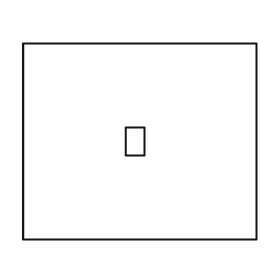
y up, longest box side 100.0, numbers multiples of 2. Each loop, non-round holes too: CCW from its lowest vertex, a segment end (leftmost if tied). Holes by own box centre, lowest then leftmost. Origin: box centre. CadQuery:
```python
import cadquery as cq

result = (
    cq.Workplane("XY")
    .moveTo(-50.0, -42.0)
    .lineTo(50.0, -42.0)
    .lineTo(50.0, 42.0)
    .lineTo(-50.0, 42.0)
    .close()
    .moveTo(-6.0, -6.0)
    .lineTo(2.0, -6.0)
    .lineTo(2.0, 6.0)
    .lineTo(-6.0, 6.0)
    .close()
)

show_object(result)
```